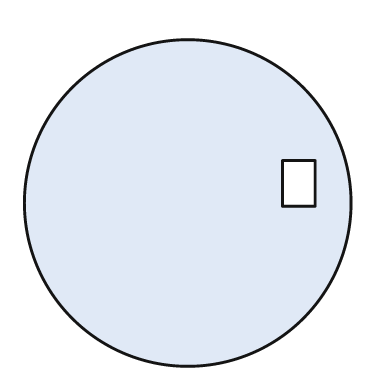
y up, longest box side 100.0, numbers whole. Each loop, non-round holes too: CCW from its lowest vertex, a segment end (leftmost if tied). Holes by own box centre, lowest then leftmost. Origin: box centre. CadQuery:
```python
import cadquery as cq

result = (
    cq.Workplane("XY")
    .moveTo(0.0, 0.0)
    .circle(50.0)
    .moveTo(29.0, -1.0)
    .lineTo(39.0, -1.0)
    .lineTo(39.0, 13.0)
    .lineTo(29.0, 13.0)
    .close()
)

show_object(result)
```